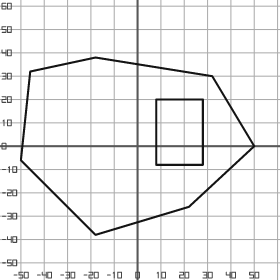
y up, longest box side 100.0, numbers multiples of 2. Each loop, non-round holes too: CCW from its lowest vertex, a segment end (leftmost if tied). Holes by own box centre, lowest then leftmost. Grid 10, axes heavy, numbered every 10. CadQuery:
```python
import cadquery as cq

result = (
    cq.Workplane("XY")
    .moveTo(-18.0, -38.0)
    .lineTo(22.0, -26.0)
    .lineTo(50.0, 0.0)
    .lineTo(32.0, 30.0)
    .lineTo(-18.0, 38.0)
    .lineTo(-46.0, 32.0)
    .lineTo(-50.0, -6.0)
    .close()
    .moveTo(8.0, -8.0)
    .lineTo(28.0, -8.0)
    .lineTo(28.0, 20.0)
    .lineTo(8.0, 20.0)
    .close()
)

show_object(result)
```